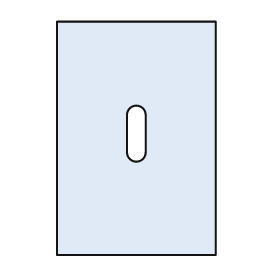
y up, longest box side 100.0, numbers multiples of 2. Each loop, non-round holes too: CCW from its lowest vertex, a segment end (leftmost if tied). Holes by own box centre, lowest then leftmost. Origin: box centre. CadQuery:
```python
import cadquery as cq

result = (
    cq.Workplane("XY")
    .moveTo(-34.0, -50.0)
    .lineTo(34.0, -50.0)
    .lineTo(34.0, 50.0)
    .lineTo(-34.0, 50.0)
    .close()
    .moveTo(-4.0, -6.0)
    .threePointArc((0.0, -10.0), (4.0, -6.0))
    .lineTo(4.0, 10.0)
    .threePointArc((0.0, 14.0), (-4.0, 10.0))
    .close()
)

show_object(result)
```